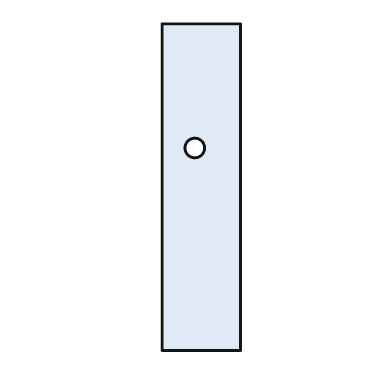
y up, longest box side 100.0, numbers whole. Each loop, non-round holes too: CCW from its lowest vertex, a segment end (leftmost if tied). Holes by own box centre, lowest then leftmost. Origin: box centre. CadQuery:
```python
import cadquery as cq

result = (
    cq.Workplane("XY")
    .moveTo(-12.0, -50.0)
    .lineTo(12.0, -50.0)
    .lineTo(12.0, 50.0)
    .lineTo(-12.0, 50.0)
    .close()
    .moveTo(-2.0, 12.0)
    .circle(3.0)
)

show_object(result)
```